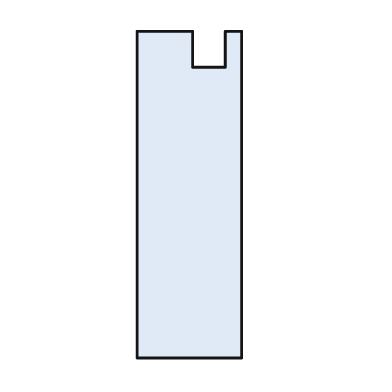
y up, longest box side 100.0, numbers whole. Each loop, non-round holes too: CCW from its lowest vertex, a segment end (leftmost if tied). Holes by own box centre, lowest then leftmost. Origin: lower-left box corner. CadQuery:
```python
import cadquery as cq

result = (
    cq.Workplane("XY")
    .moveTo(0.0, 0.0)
    .lineTo(32.0, 0.0)
    .lineTo(32.0, 100.0)
    .lineTo(27.0, 100.0)
    .lineTo(27.0, 89.0)
    .lineTo(17.0, 89.0)
    .lineTo(17.0, 100.0)
    .lineTo(0.0, 100.0)
    .close()
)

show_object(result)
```